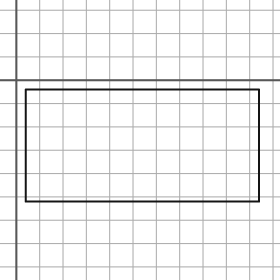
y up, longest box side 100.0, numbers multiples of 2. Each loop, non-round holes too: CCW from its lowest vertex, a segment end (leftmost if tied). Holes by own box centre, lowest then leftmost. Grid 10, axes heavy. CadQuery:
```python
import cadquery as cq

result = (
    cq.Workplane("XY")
    .moveTo(4.0, -52.0)
    .lineTo(104.0, -52.0)
    .lineTo(104.0, -4.0)
    .lineTo(4.0, -4.0)
    .close()
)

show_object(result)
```